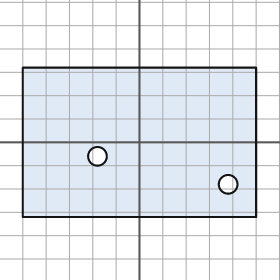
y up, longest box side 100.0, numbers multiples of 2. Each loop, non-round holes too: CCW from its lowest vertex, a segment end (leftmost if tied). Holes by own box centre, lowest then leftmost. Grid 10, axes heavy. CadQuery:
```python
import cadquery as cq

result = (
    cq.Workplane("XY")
    .moveTo(-50.0, -32.0)
    .lineTo(50.0, -32.0)
    .lineTo(50.0, 32.0)
    .lineTo(-50.0, 32.0)
    .close()
    .moveTo(38.0, -18.0)
    .circle(4.0)
    .moveTo(-18.0, -6.0)
    .circle(4.0)
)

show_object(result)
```